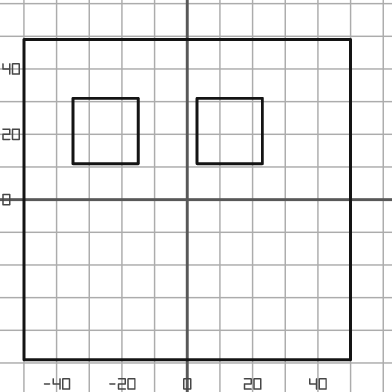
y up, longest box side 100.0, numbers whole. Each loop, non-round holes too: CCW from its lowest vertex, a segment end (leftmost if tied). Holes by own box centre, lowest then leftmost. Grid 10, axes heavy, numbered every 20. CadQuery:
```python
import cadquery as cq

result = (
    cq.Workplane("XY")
    .moveTo(-50.0, -49.0)
    .lineTo(50.0, -49.0)
    .lineTo(50.0, 49.0)
    .lineTo(-50.0, 49.0)
    .close()
    .moveTo(-35.0, 11.0)
    .lineTo(-15.0, 11.0)
    .lineTo(-15.0, 31.0)
    .lineTo(-35.0, 31.0)
    .close()
    .moveTo(3.0, 11.0)
    .lineTo(23.0, 11.0)
    .lineTo(23.0, 31.0)
    .lineTo(3.0, 31.0)
    .close()
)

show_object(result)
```